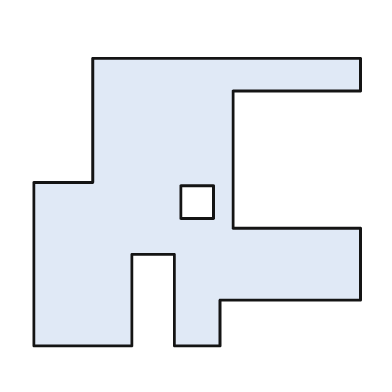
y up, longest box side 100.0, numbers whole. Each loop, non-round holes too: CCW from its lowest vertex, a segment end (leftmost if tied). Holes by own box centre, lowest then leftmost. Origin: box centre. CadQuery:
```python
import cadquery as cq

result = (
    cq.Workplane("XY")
    .moveTo(-50.0, -44.0)
    .lineTo(-20.0, -44.0)
    .lineTo(-20.0, -16.0)
    .lineTo(-7.0, -16.0)
    .lineTo(-7.0, -44.0)
    .lineTo(7.0, -44.0)
    .lineTo(7.0, -30.0)
    .lineTo(50.0, -30.0)
    .lineTo(50.0, -8.0)
    .lineTo(11.0, -8.0)
    .lineTo(11.0, 34.0)
    .lineTo(50.0, 34.0)
    .lineTo(50.0, 44.0)
    .lineTo(-32.0, 44.0)
    .lineTo(-32.0, 6.0)
    .lineTo(-50.0, 6.0)
    .close()
    .moveTo(-5.0, -5.0)
    .lineTo(5.0, -5.0)
    .lineTo(5.0, 5.0)
    .lineTo(-5.0, 5.0)
    .close()
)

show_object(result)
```